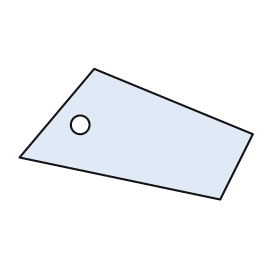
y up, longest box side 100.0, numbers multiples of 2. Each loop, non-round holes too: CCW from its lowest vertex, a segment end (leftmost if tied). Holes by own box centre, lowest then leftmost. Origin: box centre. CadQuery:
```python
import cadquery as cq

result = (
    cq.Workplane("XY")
    .moveTo(36.0, -28.0)
    .lineTo(50.0, 0.0)
    .lineTo(-18.0, 28.0)
    .lineTo(-50.0, -10.0)
    .close()
    .moveTo(-24.0, 4.0)
    .circle(4.0)
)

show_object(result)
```